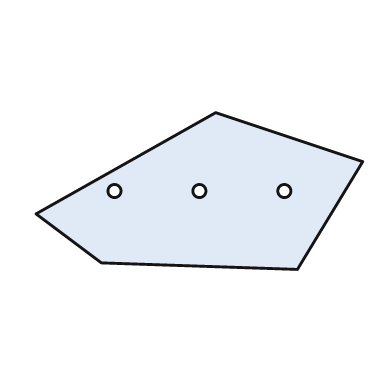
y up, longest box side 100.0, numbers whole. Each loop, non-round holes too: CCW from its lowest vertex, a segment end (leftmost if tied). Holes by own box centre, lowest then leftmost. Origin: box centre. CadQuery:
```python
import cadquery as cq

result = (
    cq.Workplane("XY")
    .moveTo(30.0, -24.0)
    .lineTo(50.0, 9.0)
    .lineTo(5.0, 24.0)
    .lineTo(-50.0, -7.0)
    .lineTo(-30.0, -22.0)
    .close()
    .moveTo(-26.0, 0.0)
    .circle(2.0)
    .moveTo(0.0, 0.0)
    .circle(2.0)
    .moveTo(26.0, 0.0)
    .circle(2.0)
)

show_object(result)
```